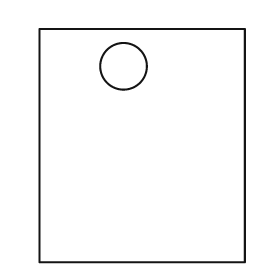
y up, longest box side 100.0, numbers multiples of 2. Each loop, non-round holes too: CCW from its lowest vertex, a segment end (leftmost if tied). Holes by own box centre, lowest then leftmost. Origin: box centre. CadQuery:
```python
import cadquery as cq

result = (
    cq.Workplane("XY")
    .moveTo(-44.0, -50.0)
    .lineTo(44.0, -50.0)
    .lineTo(44.0, 50.0)
    .lineTo(-44.0, 50.0)
    .close()
    .moveTo(-8.0, 34.0)
    .circle(10.0)
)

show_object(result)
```